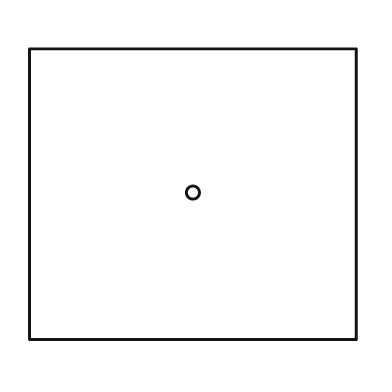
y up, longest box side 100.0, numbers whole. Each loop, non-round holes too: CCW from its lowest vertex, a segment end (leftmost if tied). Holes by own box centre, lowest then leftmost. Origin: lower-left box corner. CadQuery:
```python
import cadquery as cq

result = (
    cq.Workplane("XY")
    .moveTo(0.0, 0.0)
    .lineTo(100.0, 0.0)
    .lineTo(100.0, 89.0)
    .lineTo(0.0, 89.0)
    .close()
    .moveTo(50.0, 45.0)
    .circle(2.0)
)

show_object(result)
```